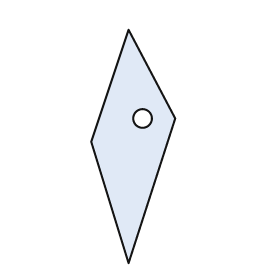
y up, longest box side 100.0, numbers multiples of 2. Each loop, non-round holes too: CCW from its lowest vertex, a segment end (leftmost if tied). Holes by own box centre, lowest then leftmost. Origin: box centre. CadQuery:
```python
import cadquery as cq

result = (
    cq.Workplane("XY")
    .moveTo(-2.0, -50.0)
    .lineTo(18.0, 12.0)
    .lineTo(-2.0, 50.0)
    .lineTo(-18.0, 2.0)
    .close()
    .moveTo(4.0, 12.0)
    .circle(4.0)
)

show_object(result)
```